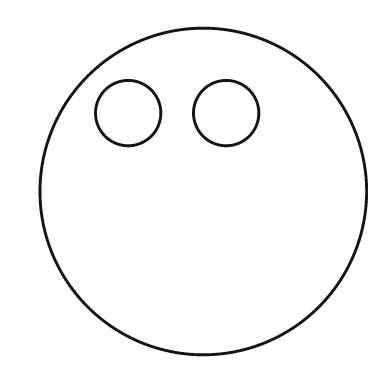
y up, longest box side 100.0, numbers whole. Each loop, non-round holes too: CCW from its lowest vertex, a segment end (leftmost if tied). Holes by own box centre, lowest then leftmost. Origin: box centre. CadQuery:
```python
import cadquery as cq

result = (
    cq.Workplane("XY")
    .moveTo(0.0, 0.0)
    .circle(50.0)
    .moveTo(-23.0, 24.0)
    .circle(10.0)
    .moveTo(7.0, 24.0)
    .circle(10.0)
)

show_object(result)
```